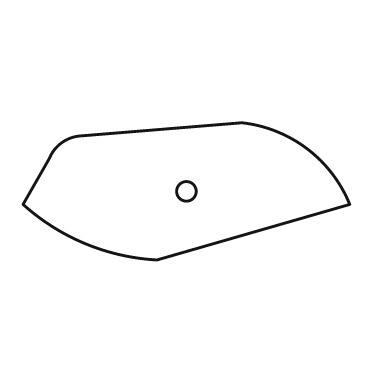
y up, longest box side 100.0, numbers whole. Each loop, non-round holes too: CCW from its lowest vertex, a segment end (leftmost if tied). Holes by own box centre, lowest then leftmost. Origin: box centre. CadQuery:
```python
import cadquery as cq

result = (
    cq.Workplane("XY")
    .moveTo(-9.0, -21.0)
    .lineTo(50.0, -4.0)
    .threePointArc((37.0, 13.0), (17.0, 21.0))
    .lineTo(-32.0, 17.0)
    .threePointArc((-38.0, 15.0), (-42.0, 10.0))
    .lineTo(-50.0, -4.0)
    .threePointArc((-31.0, -16.0), (-9.0, -21.0))
    .close()
    .moveTo(0.0, 0.0)
    .circle(3.0)
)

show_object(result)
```